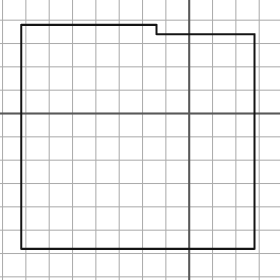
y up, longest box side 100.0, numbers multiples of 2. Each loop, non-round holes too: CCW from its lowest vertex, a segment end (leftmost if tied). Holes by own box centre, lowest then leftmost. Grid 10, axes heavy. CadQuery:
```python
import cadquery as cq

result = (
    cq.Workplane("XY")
    .moveTo(-72.0, -58.0)
    .lineTo(28.0, -58.0)
    .lineTo(28.0, 34.0)
    .lineTo(-14.0, 34.0)
    .lineTo(-14.0, 38.0)
    .lineTo(-72.0, 38.0)
    .close()
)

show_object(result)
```